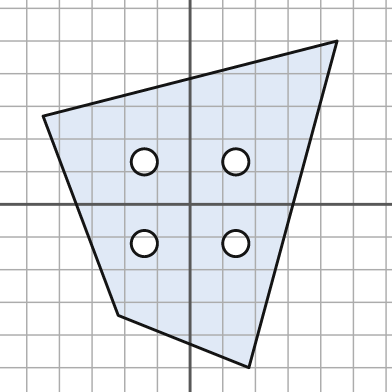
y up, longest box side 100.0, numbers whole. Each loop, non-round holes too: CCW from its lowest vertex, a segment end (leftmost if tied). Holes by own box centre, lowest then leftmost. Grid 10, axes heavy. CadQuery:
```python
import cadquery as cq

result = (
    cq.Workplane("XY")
    .moveTo(18.0, -50.0)
    .lineTo(45.0, 50.0)
    .lineTo(-45.0, 27.0)
    .lineTo(-22.0, -34.0)
    .close()
    .moveTo(-14.0, -12.0)
    .circle(4.0)
    .moveTo(14.0, -12.0)
    .circle(4.0)
    .moveTo(-14.0, 13.0)
    .circle(4.0)
    .moveTo(14.0, 13.0)
    .circle(4.0)
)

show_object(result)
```